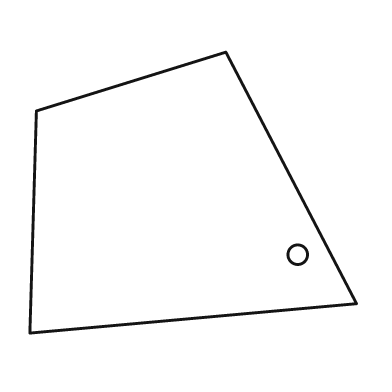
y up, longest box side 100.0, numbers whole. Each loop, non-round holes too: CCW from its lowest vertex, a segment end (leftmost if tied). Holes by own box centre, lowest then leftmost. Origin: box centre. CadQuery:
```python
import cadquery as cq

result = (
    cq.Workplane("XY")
    .moveTo(-50.0, -43.0)
    .lineTo(50.0, -34.0)
    .lineTo(10.0, 43.0)
    .lineTo(-48.0, 25.0)
    .close()
    .moveTo(32.0, -19.0)
    .circle(3.0)
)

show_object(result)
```